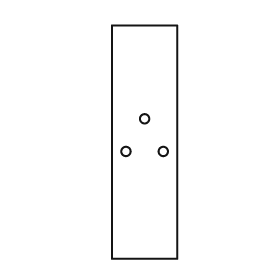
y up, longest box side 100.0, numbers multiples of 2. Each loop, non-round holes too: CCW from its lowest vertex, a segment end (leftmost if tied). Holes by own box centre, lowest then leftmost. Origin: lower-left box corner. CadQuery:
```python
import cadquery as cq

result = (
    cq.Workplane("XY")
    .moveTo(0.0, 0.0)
    .lineTo(28.0, 0.0)
    .lineTo(28.0, 100.0)
    .lineTo(0.0, 100.0)
    .close()
    .moveTo(6.0, 46.0)
    .circle(2.0)
    .moveTo(22.0, 46.0)
    .circle(2.0)
    .moveTo(14.0, 60.0)
    .circle(2.0)
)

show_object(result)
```